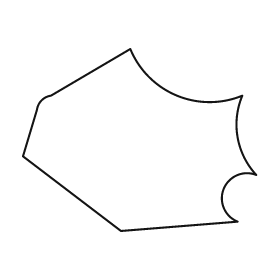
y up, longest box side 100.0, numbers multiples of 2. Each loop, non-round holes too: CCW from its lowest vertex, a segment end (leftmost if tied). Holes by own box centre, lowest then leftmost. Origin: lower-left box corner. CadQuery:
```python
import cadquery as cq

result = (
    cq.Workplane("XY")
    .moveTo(42.0, 0.0)
    .lineTo(92.0, 4.0)
    .threePointArc((86.0, 18.0), (100.0, 24.0))
    .threePointArc((92.0, 40.0), (94.0, 58.0))
    .threePointArc((66.0, 58.0), (46.0, 78.0))
    .lineTo(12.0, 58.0)
    .threePointArc((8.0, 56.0), (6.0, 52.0))
    .lineTo(0.0, 32.0)
    .close()
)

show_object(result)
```